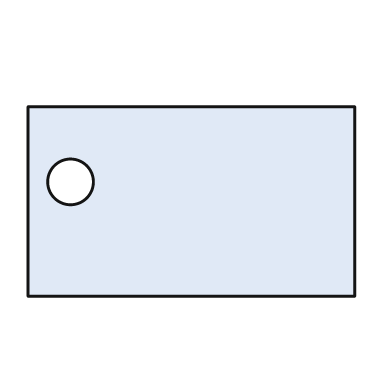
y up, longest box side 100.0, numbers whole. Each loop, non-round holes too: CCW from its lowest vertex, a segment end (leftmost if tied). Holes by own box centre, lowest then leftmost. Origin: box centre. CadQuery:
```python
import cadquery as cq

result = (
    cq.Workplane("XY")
    .moveTo(-50.0, -29.0)
    .lineTo(50.0, -29.0)
    .lineTo(50.0, 29.0)
    .lineTo(-50.0, 29.0)
    .close()
    .moveTo(-37.0, 6.0)
    .circle(7.0)
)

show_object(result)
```